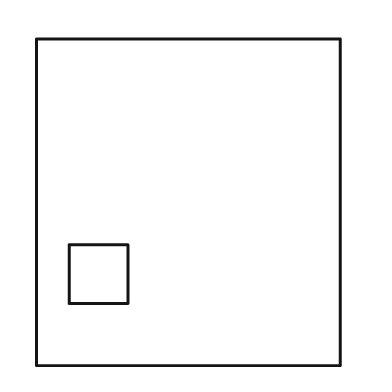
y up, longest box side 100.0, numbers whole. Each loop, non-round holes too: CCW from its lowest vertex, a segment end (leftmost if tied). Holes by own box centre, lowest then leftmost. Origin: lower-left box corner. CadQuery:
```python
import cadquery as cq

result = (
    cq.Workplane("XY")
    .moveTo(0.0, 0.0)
    .lineTo(93.0, 0.0)
    .lineTo(93.0, 100.0)
    .lineTo(0.0, 100.0)
    .close()
    .moveTo(10.0, 19.0)
    .lineTo(28.0, 19.0)
    .lineTo(28.0, 37.0)
    .lineTo(10.0, 37.0)
    .close()
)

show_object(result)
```